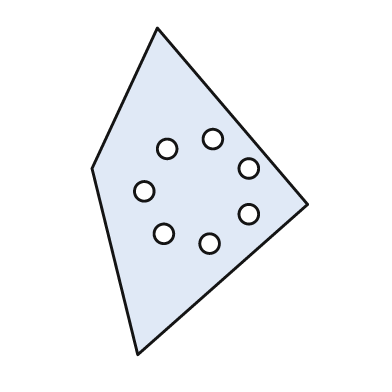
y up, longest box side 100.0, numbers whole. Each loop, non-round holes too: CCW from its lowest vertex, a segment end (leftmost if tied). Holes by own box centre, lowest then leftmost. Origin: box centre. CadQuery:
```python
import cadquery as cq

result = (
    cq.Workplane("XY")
    .moveTo(-19.0, -50.0)
    .lineTo(33.0, -4.0)
    .lineTo(-13.0, 50.0)
    .lineTo(-33.0, 7.0)
    .close()
    .moveTo(3.0, -16.0)
    .circle(3.0)
    .moveTo(-11.0, -13.0)
    .circle(3.0)
    .moveTo(15.0, -7.0)
    .circle(3.0)
    .moveTo(-17.0, 0.0)
    .circle(3.0)
    .moveTo(15.0, 7.0)
    .circle(3.0)
    .moveTo(-10.0, 13.0)
    .circle(3.0)
    .moveTo(4.0, 16.0)
    .circle(3.0)
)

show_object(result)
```